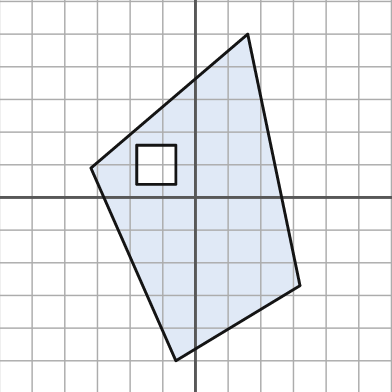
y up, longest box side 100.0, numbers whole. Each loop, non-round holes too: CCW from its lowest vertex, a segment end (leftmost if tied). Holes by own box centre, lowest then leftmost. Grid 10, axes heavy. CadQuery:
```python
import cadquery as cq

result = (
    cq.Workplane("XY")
    .moveTo(-6.0, -50.0)
    .lineTo(32.0, -27.0)
    .lineTo(16.0, 50.0)
    .lineTo(-32.0, 9.0)
    .close()
    .moveTo(-18.0, 4.0)
    .lineTo(-6.0, 4.0)
    .lineTo(-6.0, 16.0)
    .lineTo(-18.0, 16.0)
    .close()
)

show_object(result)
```